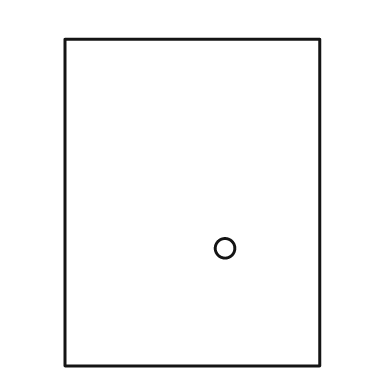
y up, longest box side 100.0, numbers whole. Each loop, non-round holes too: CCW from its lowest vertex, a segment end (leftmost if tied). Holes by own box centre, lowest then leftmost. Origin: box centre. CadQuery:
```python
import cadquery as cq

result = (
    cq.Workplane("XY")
    .moveTo(-39.0, -50.0)
    .lineTo(39.0, -50.0)
    .lineTo(39.0, 50.0)
    .lineTo(-39.0, 50.0)
    .close()
    .moveTo(10.0, -14.0)
    .circle(3.0)
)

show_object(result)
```